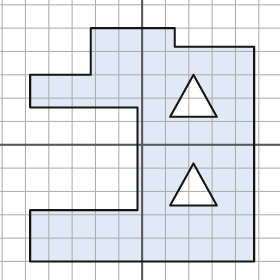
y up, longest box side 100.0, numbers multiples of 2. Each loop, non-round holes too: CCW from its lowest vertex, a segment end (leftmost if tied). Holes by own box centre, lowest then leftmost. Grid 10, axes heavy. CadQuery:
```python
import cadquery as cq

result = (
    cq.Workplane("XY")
    .moveTo(-48.0, -50.0)
    .lineTo(48.0, -50.0)
    .lineTo(48.0, 42.0)
    .lineTo(14.0, 42.0)
    .lineTo(14.0, 50.0)
    .lineTo(-22.0, 50.0)
    .lineTo(-22.0, 30.0)
    .lineTo(-48.0, 30.0)
    .lineTo(-48.0, 16.0)
    .lineTo(-2.0, 16.0)
    .lineTo(-2.0, -28.0)
    .lineTo(-48.0, -28.0)
    .close()
    .moveTo(12.0, -26.0)
    .lineTo(32.0, -26.0)
    .lineTo(22.0, -8.0)
    .close()
    .moveTo(12.0, 12.0)
    .lineTo(32.0, 12.0)
    .lineTo(22.0, 30.0)
    .close()
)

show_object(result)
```